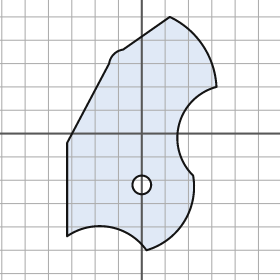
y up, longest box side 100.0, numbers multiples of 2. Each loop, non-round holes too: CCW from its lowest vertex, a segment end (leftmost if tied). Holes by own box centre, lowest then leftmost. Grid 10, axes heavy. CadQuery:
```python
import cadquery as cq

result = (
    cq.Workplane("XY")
    .moveTo(2.0, -50.0)
    .threePointArc((18.0, -38.0), (22.0, -18.0))
    .threePointArc((16.0, 4.0), (32.0, 20.0))
    .threePointArc((26.0, 38.0), (12.0, 50.0))
    .lineTo(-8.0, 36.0)
    .threePointArc((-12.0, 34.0), (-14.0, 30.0))
    .lineTo(-32.0, -4.0)
    .lineTo(-32.0, -44.0)
    .threePointArc((-14.0, -40.0), (2.0, -50.0))
    .close()
    .moveTo(0.0, -22.0)
    .circle(4.0)
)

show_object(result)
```